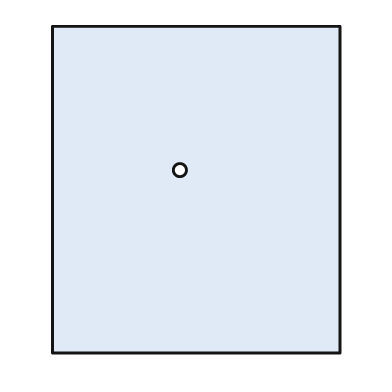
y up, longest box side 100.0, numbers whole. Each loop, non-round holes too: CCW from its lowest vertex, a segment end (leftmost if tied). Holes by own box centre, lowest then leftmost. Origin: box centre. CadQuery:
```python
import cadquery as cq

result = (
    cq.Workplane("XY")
    .moveTo(-44.0, -50.0)
    .lineTo(44.0, -50.0)
    .lineTo(44.0, 50.0)
    .lineTo(-44.0, 50.0)
    .close()
    .moveTo(-5.0, 6.0)
    .circle(2.0)
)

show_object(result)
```